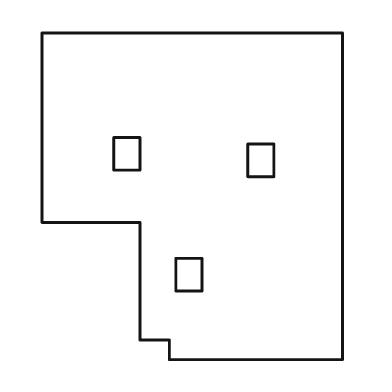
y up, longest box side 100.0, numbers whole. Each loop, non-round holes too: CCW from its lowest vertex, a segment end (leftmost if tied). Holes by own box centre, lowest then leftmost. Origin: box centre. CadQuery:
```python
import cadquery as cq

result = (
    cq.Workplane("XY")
    .moveTo(-7.0, -50.0)
    .lineTo(46.0, -50.0)
    .lineTo(46.0, 50.0)
    .lineTo(-46.0, 50.0)
    .lineTo(-46.0, -8.0)
    .lineTo(-16.0, -8.0)
    .lineTo(-16.0, -44.0)
    .lineTo(-7.0, -44.0)
    .close()
    .moveTo(-5.0, -29.0)
    .lineTo(3.0, -29.0)
    .lineTo(3.0, -19.0)
    .lineTo(-5.0, -19.0)
    .close()
    .moveTo(17.0, 6.0)
    .lineTo(25.0, 6.0)
    .lineTo(25.0, 16.0)
    .lineTo(17.0, 16.0)
    .close()
    .moveTo(-24.0, 8.0)
    .lineTo(-16.0, 8.0)
    .lineTo(-16.0, 18.0)
    .lineTo(-24.0, 18.0)
    .close()
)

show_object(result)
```